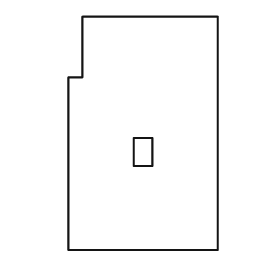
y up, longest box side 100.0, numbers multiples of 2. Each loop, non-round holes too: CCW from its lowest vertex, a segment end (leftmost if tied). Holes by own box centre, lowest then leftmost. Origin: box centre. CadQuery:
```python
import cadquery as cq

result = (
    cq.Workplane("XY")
    .moveTo(-32.0, -50.0)
    .lineTo(32.0, -50.0)
    .lineTo(32.0, 50.0)
    .lineTo(-26.0, 50.0)
    .lineTo(-26.0, 24.0)
    .lineTo(-32.0, 24.0)
    .close()
    .moveTo(-4.0, -14.0)
    .lineTo(4.0, -14.0)
    .lineTo(4.0, -2.0)
    .lineTo(-4.0, -2.0)
    .close()
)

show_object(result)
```